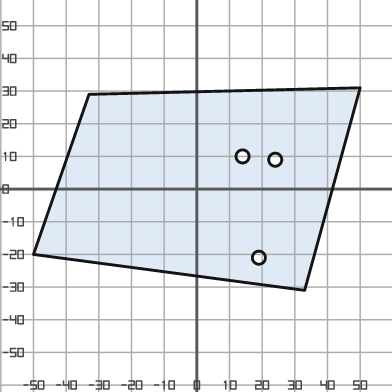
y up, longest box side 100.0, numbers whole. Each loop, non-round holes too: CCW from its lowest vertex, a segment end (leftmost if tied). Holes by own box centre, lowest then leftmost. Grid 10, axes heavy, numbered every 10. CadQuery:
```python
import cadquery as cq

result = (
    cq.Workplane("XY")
    .moveTo(33.0, -31.0)
    .lineTo(50.0, 31.0)
    .lineTo(-33.0, 29.0)
    .lineTo(-50.0, -20.0)
    .close()
    .moveTo(19.0, -21.0)
    .circle(2.0)
    .moveTo(24.0, 9.0)
    .circle(2.0)
    .moveTo(14.0, 10.0)
    .circle(2.0)
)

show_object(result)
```